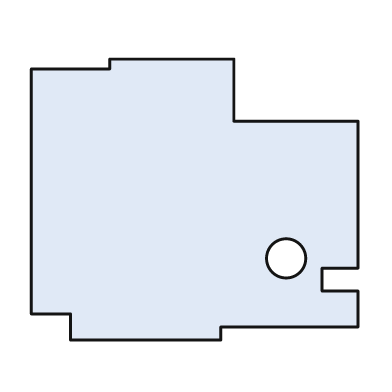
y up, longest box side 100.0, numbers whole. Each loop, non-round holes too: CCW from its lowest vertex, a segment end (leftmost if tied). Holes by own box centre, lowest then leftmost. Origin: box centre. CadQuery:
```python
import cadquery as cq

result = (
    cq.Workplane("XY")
    .moveTo(-38.0, -43.0)
    .lineTo(8.0, -43.0)
    .lineTo(8.0, -39.0)
    .lineTo(50.0, -39.0)
    .lineTo(50.0, -28.0)
    .lineTo(39.0, -28.0)
    .lineTo(39.0, -21.0)
    .lineTo(50.0, -21.0)
    .lineTo(50.0, 24.0)
    .lineTo(12.0, 24.0)
    .lineTo(12.0, 43.0)
    .lineTo(-26.0, 43.0)
    .lineTo(-26.0, 40.0)
    .lineTo(-50.0, 40.0)
    .lineTo(-50.0, -35.0)
    .lineTo(-38.0, -35.0)
    .close()
    .moveTo(28.0, -18.0)
    .circle(6.0)
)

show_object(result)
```